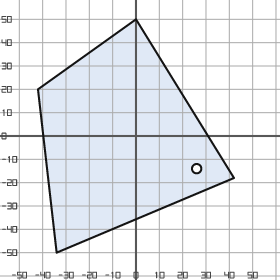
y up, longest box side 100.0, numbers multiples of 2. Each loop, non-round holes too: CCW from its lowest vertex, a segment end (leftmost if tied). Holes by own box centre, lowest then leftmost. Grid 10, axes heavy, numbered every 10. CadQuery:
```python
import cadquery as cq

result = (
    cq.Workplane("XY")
    .moveTo(-34.0, -50.0)
    .lineTo(42.0, -18.0)
    .lineTo(0.0, 50.0)
    .lineTo(-42.0, 20.0)
    .close()
    .moveTo(26.0, -14.0)
    .circle(2.0)
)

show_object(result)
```